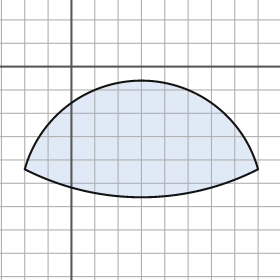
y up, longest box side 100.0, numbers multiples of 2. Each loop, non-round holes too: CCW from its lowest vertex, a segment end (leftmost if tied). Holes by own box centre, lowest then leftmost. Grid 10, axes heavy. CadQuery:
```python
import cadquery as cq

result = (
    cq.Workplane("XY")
    .moveTo(-20.0, -44.0)
    .threePointArc((30.0, -56.0), (80.0, -44.0))
    .threePointArc((30.0, -6.0), (-20.0, -44.0))
    .close()
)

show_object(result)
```